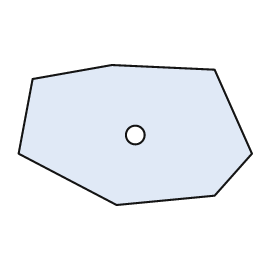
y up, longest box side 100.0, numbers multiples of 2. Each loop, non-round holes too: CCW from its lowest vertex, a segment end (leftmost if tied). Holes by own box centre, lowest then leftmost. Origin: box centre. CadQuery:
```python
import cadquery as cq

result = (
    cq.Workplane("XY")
    .moveTo(-8.0, -30.0)
    .lineTo(34.0, -26.0)
    .lineTo(50.0, -8.0)
    .lineTo(34.0, 28.0)
    .lineTo(-10.0, 30.0)
    .lineTo(-44.0, 24.0)
    .lineTo(-50.0, -8.0)
    .close()
    .moveTo(0.0, 0.0)
    .circle(4.0)
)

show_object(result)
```